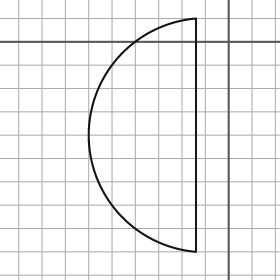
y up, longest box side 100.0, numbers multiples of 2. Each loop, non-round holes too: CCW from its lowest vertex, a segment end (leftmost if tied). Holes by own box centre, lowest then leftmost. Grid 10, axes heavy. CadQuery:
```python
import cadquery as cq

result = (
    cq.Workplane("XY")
    .moveTo(-14.0, -90.0)
    .lineTo(-14.0, 10.0)
    .threePointArc((-60.0, -40.0), (-14.0, -90.0))
    .close()
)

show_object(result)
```